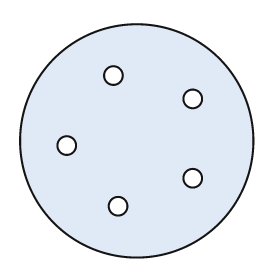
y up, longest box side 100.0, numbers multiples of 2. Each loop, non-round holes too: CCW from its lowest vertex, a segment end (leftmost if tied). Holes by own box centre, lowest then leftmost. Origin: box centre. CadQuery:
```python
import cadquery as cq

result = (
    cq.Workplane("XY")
    .moveTo(0.0, 0.0)
    .circle(50.0)
    .moveTo(-8.0, -28.0)
    .circle(4.0)
    .moveTo(24.0, -16.0)
    .circle(4.0)
    .moveTo(-30.0, -2.0)
    .circle(4.0)
    .moveTo(24.0, 18.0)
    .circle(4.0)
    .moveTo(-10.0, 28.0)
    .circle(4.0)
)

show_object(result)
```